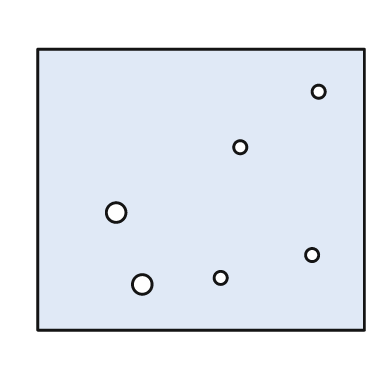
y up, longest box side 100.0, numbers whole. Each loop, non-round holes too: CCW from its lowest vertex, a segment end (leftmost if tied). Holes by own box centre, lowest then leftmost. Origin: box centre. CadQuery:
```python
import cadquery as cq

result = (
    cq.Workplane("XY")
    .moveTo(-50.0, -43.0)
    .lineTo(50.0, -43.0)
    .lineTo(50.0, 43.0)
    .lineTo(-50.0, 43.0)
    .close()
    .moveTo(-18.0, -29.0)
    .circle(3.0)
    .moveTo(6.0, -27.0)
    .circle(2.0)
    .moveTo(34.0, -20.0)
    .circle(2.0)
    .moveTo(-26.0, -7.0)
    .circle(3.0)
    .moveTo(12.0, 13.0)
    .circle(2.0)
    .moveTo(36.0, 30.0)
    .circle(2.0)
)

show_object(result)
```